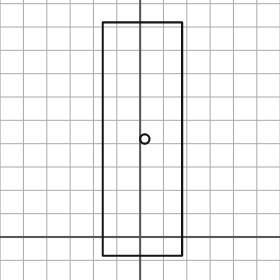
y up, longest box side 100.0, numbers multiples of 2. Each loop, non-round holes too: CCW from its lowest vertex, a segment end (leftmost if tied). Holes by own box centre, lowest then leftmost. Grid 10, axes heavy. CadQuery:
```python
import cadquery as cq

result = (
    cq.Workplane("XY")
    .moveTo(-16.0, -8.0)
    .lineTo(18.0, -8.0)
    .lineTo(18.0, 92.0)
    .lineTo(-16.0, 92.0)
    .close()
    .moveTo(2.0, 42.0)
    .circle(2.0)
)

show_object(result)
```